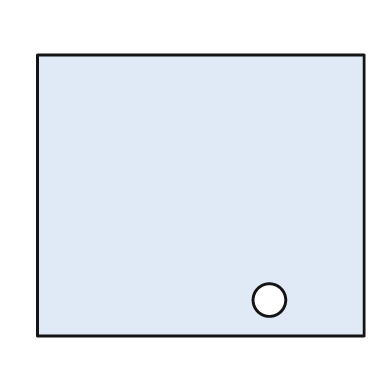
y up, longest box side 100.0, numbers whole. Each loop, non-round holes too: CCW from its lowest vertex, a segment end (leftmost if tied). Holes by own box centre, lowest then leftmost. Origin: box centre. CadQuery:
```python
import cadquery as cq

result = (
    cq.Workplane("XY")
    .moveTo(-50.0, -43.0)
    .lineTo(50.0, -43.0)
    .lineTo(50.0, 43.0)
    .lineTo(-50.0, 43.0)
    .close()
    .moveTo(21.0, -32.0)
    .circle(5.0)
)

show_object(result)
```